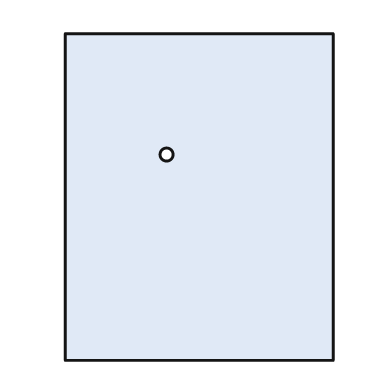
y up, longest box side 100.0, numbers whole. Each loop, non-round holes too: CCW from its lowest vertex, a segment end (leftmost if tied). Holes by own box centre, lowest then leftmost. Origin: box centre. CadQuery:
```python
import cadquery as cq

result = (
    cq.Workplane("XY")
    .moveTo(-41.0, -50.0)
    .lineTo(41.0, -50.0)
    .lineTo(41.0, 50.0)
    .lineTo(-41.0, 50.0)
    .close()
    .moveTo(-10.0, 13.0)
    .circle(2.0)
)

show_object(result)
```